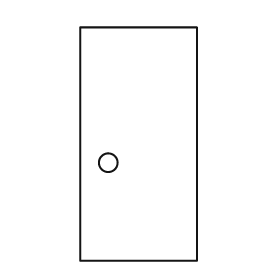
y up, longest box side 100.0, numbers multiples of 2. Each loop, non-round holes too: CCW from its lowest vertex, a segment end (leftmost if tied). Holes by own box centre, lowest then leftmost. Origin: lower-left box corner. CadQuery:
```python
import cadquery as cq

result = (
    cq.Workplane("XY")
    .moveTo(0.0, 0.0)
    .lineTo(50.0, 0.0)
    .lineTo(50.0, 100.0)
    .lineTo(0.0, 100.0)
    .close()
    .moveTo(12.0, 42.0)
    .circle(4.0)
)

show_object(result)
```